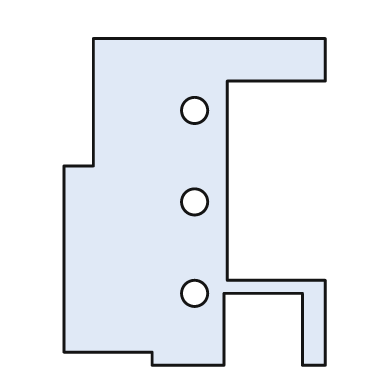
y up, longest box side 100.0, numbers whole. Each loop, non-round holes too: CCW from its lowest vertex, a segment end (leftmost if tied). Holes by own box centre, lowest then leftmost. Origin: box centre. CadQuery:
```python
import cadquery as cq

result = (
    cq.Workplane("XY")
    .moveTo(-13.0, -50.0)
    .lineTo(9.0, -50.0)
    .lineTo(9.0, -28.0)
    .lineTo(33.0, -28.0)
    .lineTo(33.0, -50.0)
    .lineTo(40.0, -50.0)
    .lineTo(40.0, -24.0)
    .lineTo(10.0, -24.0)
    .lineTo(10.0, 37.0)
    .lineTo(40.0, 37.0)
    .lineTo(40.0, 50.0)
    .lineTo(-31.0, 50.0)
    .lineTo(-31.0, 11.0)
    .lineTo(-40.0, 11.0)
    .lineTo(-40.0, -46.0)
    .lineTo(-13.0, -46.0)
    .close()
    .moveTo(0.0, -28.0)
    .circle(4.0)
    .moveTo(0.0, 0.0)
    .circle(4.0)
    .moveTo(0.0, 28.0)
    .circle(4.0)
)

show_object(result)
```